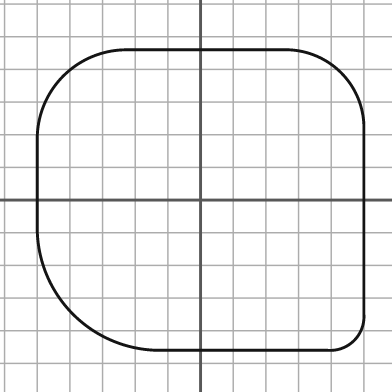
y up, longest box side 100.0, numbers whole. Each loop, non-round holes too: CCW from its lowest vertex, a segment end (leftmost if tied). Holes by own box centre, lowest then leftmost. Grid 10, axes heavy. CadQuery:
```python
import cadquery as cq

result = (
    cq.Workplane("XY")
    .moveTo(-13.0, -46.0)
    .lineTo(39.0, -46.0)
    .threePointArc((47.0, -43.0), (50.0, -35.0))
    .lineTo(50.0, 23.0)
    .threePointArc((43.0, 39.0), (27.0, 46.0))
    .lineTo(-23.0, 46.0)
    .threePointArc((-42.0, 38.0), (-50.0, 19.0))
    .lineTo(-50.0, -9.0)
    .threePointArc((-39.0, -35.0), (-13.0, -46.0))
    .close()
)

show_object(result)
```